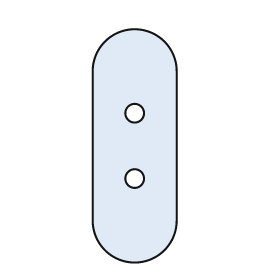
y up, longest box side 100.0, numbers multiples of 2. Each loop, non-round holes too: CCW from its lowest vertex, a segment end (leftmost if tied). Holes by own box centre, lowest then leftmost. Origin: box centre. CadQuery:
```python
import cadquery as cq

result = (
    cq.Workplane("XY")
    .moveTo(-18.0, -32.0)
    .threePointArc((0.0, -50.0), (18.0, -32.0))
    .lineTo(18.0, 32.0)
    .threePointArc((0.0, 50.0), (-18.0, 32.0))
    .close()
    .moveTo(0.0, -14.0)
    .circle(4.0)
    .moveTo(0.0, 14.0)
    .circle(4.0)
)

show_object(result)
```